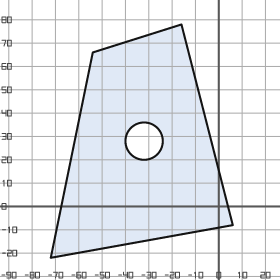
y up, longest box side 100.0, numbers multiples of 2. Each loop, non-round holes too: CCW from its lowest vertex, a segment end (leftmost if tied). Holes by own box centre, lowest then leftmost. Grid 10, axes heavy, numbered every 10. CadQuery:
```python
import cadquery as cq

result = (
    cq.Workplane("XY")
    .moveTo(-72.0, -22.0)
    .lineTo(6.0, -8.0)
    .lineTo(-16.0, 78.0)
    .lineTo(-54.0, 66.0)
    .close()
    .moveTo(-32.0, 28.0)
    .circle(8.0)
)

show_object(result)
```